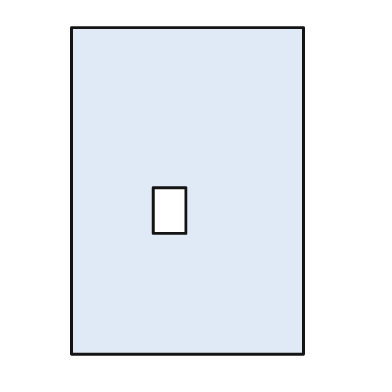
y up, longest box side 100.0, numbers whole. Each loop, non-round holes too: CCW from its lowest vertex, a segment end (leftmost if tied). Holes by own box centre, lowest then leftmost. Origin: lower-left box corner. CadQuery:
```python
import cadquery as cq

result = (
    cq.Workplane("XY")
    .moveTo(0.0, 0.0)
    .lineTo(71.0, 0.0)
    .lineTo(71.0, 100.0)
    .lineTo(0.0, 100.0)
    .close()
    .moveTo(25.0, 37.0)
    .lineTo(35.0, 37.0)
    .lineTo(35.0, 51.0)
    .lineTo(25.0, 51.0)
    .close()
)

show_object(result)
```